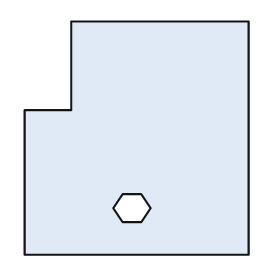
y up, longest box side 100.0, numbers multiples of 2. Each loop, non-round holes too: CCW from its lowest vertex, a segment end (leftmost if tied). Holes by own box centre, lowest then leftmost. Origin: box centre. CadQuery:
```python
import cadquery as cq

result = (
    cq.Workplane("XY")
    .moveTo(-48.0, -50.0)
    .lineTo(48.0, -50.0)
    .lineTo(48.0, 50.0)
    .lineTo(-28.0, 50.0)
    .lineTo(-28.0, 12.0)
    .lineTo(-48.0, 12.0)
    .close()
    .moveTo(-6.0, -36.0)
    .lineTo(2.0, -36.0)
    .lineTo(6.0, -30.0)
    .lineTo(2.0, -24.0)
    .lineTo(-6.0, -24.0)
    .lineTo(-10.0, -30.0)
    .close()
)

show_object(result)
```